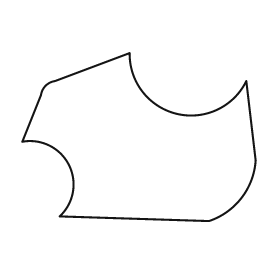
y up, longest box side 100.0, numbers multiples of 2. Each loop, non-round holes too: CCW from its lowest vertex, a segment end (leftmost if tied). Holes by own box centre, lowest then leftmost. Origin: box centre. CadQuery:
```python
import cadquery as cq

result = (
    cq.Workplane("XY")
    .moveTo(30.0, -36.0)
    .threePointArc((44.0, -26.0), (50.0, -10.0))
    .lineTo(46.0, 24.0)
    .threePointArc((16.0, 10.0), (-4.0, 36.0))
    .lineTo(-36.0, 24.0)
    .threePointArc((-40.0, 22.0), (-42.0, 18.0))
    .lineTo(-50.0, -2.0)
    .threePointArc((-30.0, -12.0), (-34.0, -34.0))
    .close()
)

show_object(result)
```